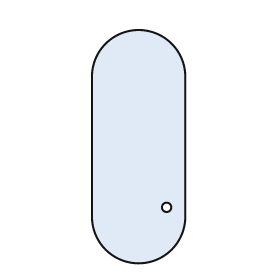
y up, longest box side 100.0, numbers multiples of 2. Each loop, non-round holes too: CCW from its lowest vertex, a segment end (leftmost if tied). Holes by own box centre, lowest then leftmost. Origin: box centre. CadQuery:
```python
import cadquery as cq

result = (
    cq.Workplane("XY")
    .moveTo(-20.0, -30.0)
    .threePointArc((0.0, -50.0), (20.0, -30.0))
    .lineTo(20.0, 30.0)
    .threePointArc((0.0, 50.0), (-20.0, 30.0))
    .close()
    .moveTo(12.0, -26.0)
    .circle(2.0)
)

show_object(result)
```